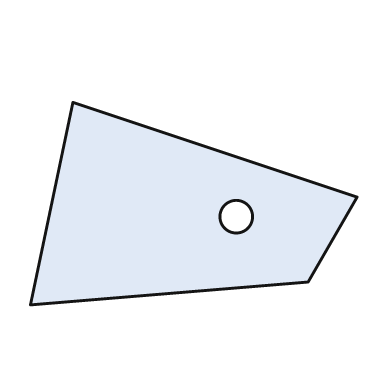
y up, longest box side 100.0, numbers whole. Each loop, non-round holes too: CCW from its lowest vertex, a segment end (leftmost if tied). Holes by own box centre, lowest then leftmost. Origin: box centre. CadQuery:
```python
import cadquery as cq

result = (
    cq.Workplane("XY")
    .moveTo(-50.0, -31.0)
    .lineTo(35.0, -24.0)
    .lineTo(50.0, 2.0)
    .lineTo(-37.0, 31.0)
    .close()
    .moveTo(13.0, -4.0)
    .circle(5.0)
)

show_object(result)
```